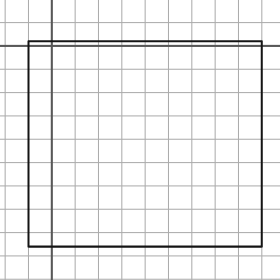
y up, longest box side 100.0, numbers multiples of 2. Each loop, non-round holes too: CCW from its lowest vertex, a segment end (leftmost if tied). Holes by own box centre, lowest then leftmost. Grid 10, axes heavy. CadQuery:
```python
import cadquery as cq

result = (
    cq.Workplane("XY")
    .moveTo(-10.0, -86.0)
    .lineTo(90.0, -86.0)
    .lineTo(90.0, 2.0)
    .lineTo(-10.0, 2.0)
    .close()
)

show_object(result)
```